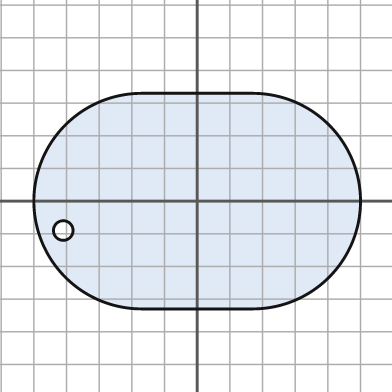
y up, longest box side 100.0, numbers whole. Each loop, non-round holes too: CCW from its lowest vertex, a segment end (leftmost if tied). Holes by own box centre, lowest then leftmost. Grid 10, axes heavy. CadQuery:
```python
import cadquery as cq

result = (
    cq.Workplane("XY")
    .moveTo(-17.0, -33.0)
    .lineTo(17.0, -33.0)
    .threePointArc((50.0, 0.0), (17.0, 33.0))
    .lineTo(-17.0, 33.0)
    .threePointArc((-50.0, 0.0), (-17.0, -33.0))
    .close()
    .moveTo(-41.0, -9.0)
    .circle(3.0)
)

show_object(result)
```